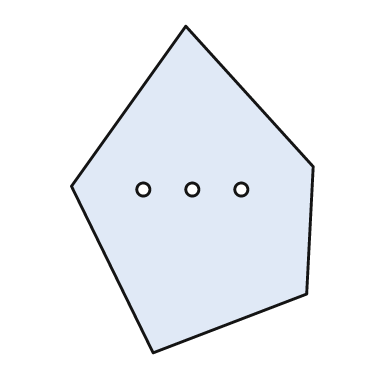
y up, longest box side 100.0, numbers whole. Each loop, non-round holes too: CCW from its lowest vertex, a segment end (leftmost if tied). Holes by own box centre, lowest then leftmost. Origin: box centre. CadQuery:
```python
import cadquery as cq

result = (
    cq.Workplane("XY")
    .moveTo(-12.0, -50.0)
    .lineTo(35.0, -32.0)
    .lineTo(37.0, 7.0)
    .lineTo(-2.0, 50.0)
    .lineTo(-37.0, 1.0)
    .close()
    .moveTo(-15.0, 0.0)
    .circle(2.0)
    .moveTo(0.0, 0.0)
    .circle(2.0)
    .moveTo(15.0, 0.0)
    .circle(2.0)
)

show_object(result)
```